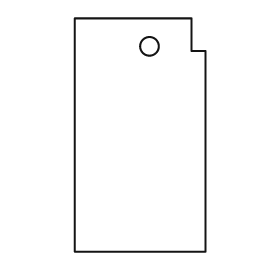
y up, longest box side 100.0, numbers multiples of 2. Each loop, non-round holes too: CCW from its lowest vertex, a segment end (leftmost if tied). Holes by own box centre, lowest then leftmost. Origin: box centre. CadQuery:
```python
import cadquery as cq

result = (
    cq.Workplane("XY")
    .moveTo(-28.0, -50.0)
    .lineTo(28.0, -50.0)
    .lineTo(28.0, 36.0)
    .lineTo(22.0, 36.0)
    .lineTo(22.0, 50.0)
    .lineTo(-28.0, 50.0)
    .close()
    .moveTo(4.0, 38.0)
    .circle(4.0)
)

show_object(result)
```